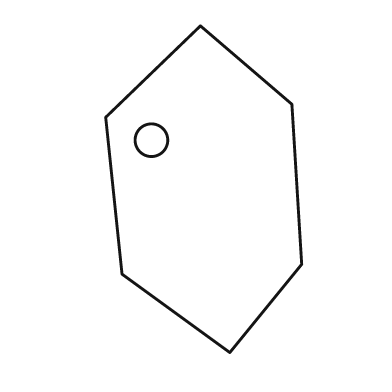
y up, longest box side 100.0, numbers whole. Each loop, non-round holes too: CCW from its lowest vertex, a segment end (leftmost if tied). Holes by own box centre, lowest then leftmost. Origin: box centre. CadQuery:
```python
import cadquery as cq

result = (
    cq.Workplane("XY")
    .moveTo(8.0, -50.0)
    .lineTo(30.0, -23.0)
    .lineTo(27.0, 26.0)
    .lineTo(-1.0, 50.0)
    .lineTo(-30.0, 22.0)
    .lineTo(-25.0, -26.0)
    .close()
    .moveTo(-16.0, 15.0)
    .circle(5.0)
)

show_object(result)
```